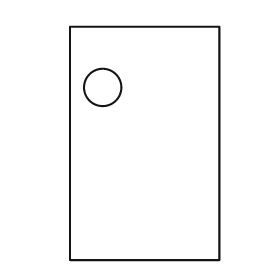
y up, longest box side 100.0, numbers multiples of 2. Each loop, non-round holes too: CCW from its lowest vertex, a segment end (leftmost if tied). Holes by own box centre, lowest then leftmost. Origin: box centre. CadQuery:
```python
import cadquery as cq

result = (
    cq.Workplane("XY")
    .moveTo(-32.0, -50.0)
    .lineTo(32.0, -50.0)
    .lineTo(32.0, 50.0)
    .lineTo(-32.0, 50.0)
    .close()
    .moveTo(-18.0, 24.0)
    .circle(8.0)
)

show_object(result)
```